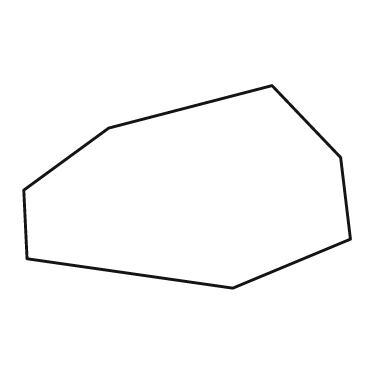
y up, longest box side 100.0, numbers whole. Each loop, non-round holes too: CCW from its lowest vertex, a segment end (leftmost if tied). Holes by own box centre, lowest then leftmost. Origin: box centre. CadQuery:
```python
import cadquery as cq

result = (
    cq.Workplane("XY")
    .moveTo(14.0, -31.0)
    .lineTo(50.0, -16.0)
    .lineTo(47.0, 9.0)
    .lineTo(26.0, 31.0)
    .lineTo(-24.0, 18.0)
    .lineTo(-50.0, -1.0)
    .lineTo(-49.0, -22.0)
    .close()
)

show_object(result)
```